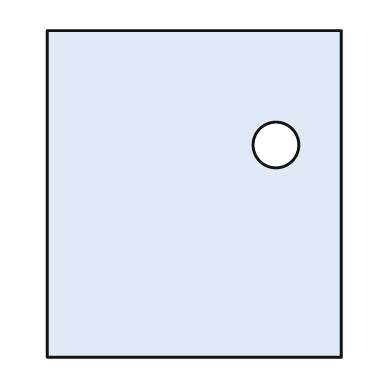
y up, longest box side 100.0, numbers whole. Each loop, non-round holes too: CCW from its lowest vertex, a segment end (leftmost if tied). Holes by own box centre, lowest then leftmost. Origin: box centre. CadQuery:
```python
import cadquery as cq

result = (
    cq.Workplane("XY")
    .moveTo(-45.0, -50.0)
    .lineTo(45.0, -50.0)
    .lineTo(45.0, 50.0)
    .lineTo(-45.0, 50.0)
    .close()
    .moveTo(25.0, 15.0)
    .circle(7.0)
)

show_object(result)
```